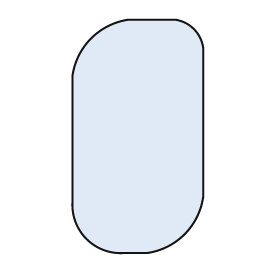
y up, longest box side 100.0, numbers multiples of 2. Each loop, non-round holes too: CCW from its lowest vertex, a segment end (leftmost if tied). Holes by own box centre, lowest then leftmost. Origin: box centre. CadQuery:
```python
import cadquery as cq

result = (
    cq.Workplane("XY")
    .moveTo(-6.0, -50.0)
    .lineTo(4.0, -50.0)
    .threePointArc((20.0, -42.0), (28.0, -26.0))
    .lineTo(28.0, 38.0)
    .threePointArc((24.0, 46.0), (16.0, 50.0))
    .lineTo(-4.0, 50.0)
    .threePointArc((-20.0, 42.0), (-28.0, 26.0))
    .lineTo(-28.0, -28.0)
    .threePointArc((-22.0, -44.0), (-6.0, -50.0))
    .close()
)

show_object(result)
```